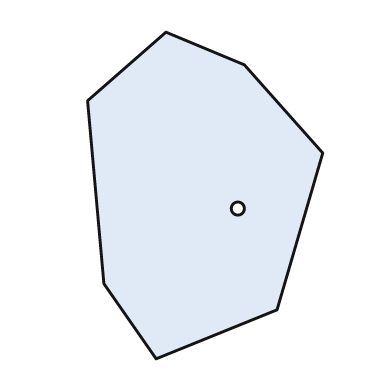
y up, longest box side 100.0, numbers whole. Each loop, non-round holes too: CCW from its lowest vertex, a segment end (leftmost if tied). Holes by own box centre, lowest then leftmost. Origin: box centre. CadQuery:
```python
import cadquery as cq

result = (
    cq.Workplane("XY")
    .moveTo(-15.0, -50.0)
    .lineTo(22.0, -35.0)
    .lineTo(36.0, 13.0)
    .lineTo(12.0, 40.0)
    .lineTo(-12.0, 50.0)
    .lineTo(-36.0, 29.0)
    .lineTo(-31.0, -27.0)
    .close()
    .moveTo(10.0, -4.0)
    .circle(2.0)
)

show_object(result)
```